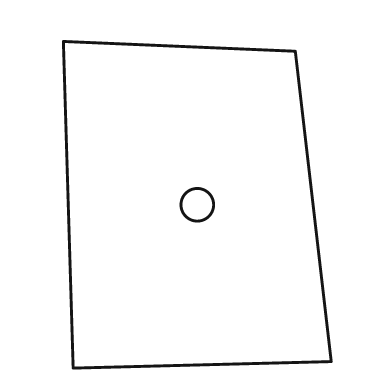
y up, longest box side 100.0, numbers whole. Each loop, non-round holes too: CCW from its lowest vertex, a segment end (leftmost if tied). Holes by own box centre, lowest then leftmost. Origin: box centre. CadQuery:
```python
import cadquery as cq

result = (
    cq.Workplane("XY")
    .moveTo(-38.0, -50.0)
    .lineTo(41.0, -48.0)
    .lineTo(30.0, 47.0)
    .lineTo(-41.0, 50.0)
    .close()
    .moveTo(0.0, 0.0)
    .circle(5.0)
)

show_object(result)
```